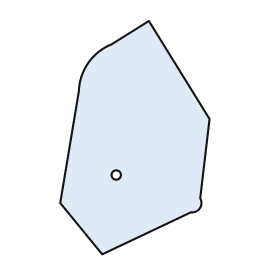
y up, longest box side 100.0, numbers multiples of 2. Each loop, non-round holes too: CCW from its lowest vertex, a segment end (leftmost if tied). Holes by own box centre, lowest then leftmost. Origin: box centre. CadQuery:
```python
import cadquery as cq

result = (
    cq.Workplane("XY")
    .moveTo(-14.0, -50.0)
    .lineTo(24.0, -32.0)
    .threePointArc((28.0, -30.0), (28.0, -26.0))
    .lineTo(32.0, 8.0)
    .lineTo(6.0, 50.0)
    .lineTo(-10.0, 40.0)
    .threePointArc((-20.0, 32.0), (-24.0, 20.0))
    .lineTo(-32.0, -28.0)
    .close()
    .moveTo(-8.0, -16.0)
    .circle(2.0)
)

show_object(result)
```